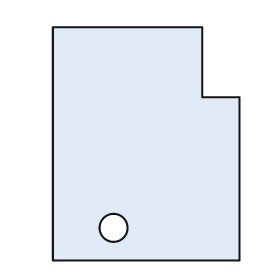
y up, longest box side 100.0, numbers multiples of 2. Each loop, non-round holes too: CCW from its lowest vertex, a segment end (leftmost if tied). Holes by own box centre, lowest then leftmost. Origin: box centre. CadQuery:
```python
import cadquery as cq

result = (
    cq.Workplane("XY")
    .moveTo(-40.0, -50.0)
    .lineTo(40.0, -50.0)
    .lineTo(40.0, 20.0)
    .lineTo(24.0, 20.0)
    .lineTo(24.0, 50.0)
    .lineTo(-40.0, 50.0)
    .close()
    .moveTo(-14.0, -36.0)
    .circle(6.0)
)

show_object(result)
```